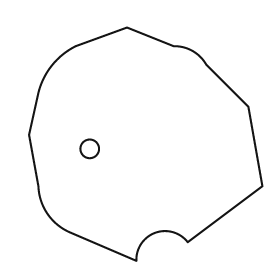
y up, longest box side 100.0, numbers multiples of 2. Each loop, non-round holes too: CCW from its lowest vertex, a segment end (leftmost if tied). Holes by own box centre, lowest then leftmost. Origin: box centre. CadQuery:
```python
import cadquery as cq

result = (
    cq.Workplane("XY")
    .moveTo(-4.0, -50.0)
    .threePointArc((4.0, -38.0), (18.0, -42.0))
    .lineTo(50.0, -18.0)
    .lineTo(44.0, 16.0)
    .lineTo(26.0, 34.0)
    .threePointArc((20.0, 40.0), (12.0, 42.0))
    .lineTo(-8.0, 50.0)
    .lineTo(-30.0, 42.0)
    .threePointArc((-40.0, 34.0), (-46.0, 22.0))
    .lineTo(-50.0, 4.0)
    .lineTo(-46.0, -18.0)
    .threePointArc((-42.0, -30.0), (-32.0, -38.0))
    .close()
    .moveTo(-24.0, -2.0)
    .circle(4.0)
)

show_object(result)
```